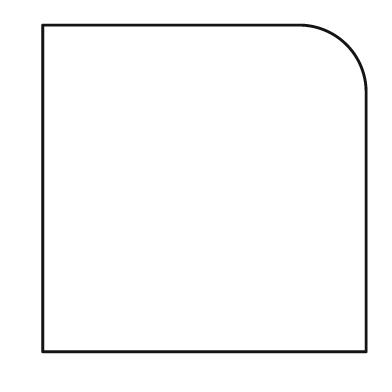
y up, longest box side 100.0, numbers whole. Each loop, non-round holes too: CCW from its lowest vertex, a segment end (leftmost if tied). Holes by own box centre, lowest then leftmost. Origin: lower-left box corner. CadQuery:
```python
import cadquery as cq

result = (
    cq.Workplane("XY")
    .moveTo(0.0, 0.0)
    .lineTo(99.0, 0.0)
    .lineTo(99.0, 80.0)
    .threePointArc((93.0, 94.0), (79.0, 100.0))
    .lineTo(0.0, 100.0)
    .close()
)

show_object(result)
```